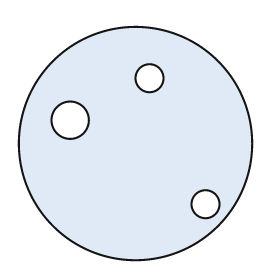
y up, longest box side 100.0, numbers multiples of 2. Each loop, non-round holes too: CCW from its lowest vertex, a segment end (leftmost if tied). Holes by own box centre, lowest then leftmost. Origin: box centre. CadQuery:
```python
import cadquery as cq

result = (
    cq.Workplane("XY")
    .moveTo(0.0, 0.0)
    .circle(50.0)
    .moveTo(30.0, -26.0)
    .circle(6.0)
    .moveTo(-28.0, 10.0)
    .circle(8.0)
    .moveTo(6.0, 28.0)
    .circle(6.0)
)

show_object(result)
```